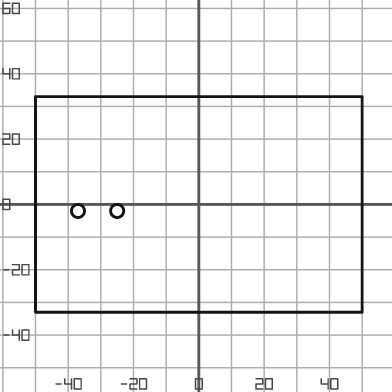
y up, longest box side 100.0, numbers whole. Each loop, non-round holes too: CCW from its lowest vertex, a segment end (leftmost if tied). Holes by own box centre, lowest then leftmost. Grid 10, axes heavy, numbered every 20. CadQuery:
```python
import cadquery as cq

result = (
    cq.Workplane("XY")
    .moveTo(-50.0, -33.0)
    .lineTo(50.0, -33.0)
    .lineTo(50.0, 33.0)
    .lineTo(-50.0, 33.0)
    .close()
    .moveTo(-37.0, -2.0)
    .circle(2.0)
    .moveTo(-25.0, -2.0)
    .circle(2.0)
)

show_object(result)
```